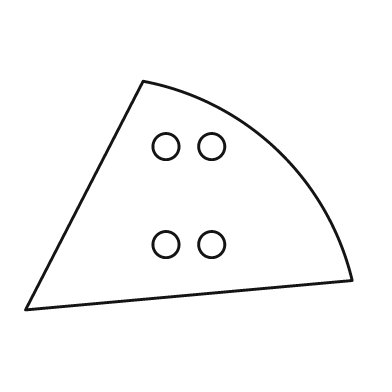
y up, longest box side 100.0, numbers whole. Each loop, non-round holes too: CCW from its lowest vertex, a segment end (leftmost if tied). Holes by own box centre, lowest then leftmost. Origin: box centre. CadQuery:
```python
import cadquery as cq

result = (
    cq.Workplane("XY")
    .moveTo(-50.0, -35.0)
    .lineTo(50.0, -26.0)
    .threePointArc((27.0, 14.0), (-14.0, 35.0))
    .close()
    .moveTo(-7.0, -15.0)
    .circle(4.0)
    .moveTo(7.0, -15.0)
    .circle(4.0)
    .moveTo(-7.0, 15.0)
    .circle(4.0)
    .moveTo(7.0, 15.0)
    .circle(4.0)
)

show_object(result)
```